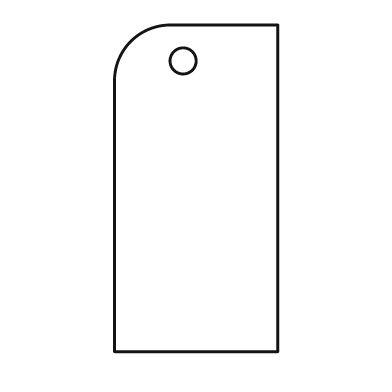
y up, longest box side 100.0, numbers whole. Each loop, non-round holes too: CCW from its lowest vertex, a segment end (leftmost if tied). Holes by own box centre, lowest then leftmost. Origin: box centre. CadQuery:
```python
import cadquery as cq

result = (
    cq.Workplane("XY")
    .moveTo(-25.0, -50.0)
    .lineTo(25.0, -50.0)
    .lineTo(25.0, 50.0)
    .lineTo(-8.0, 50.0)
    .threePointArc((-20.0, 45.0), (-25.0, 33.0))
    .close()
    .moveTo(-4.0, 39.0)
    .circle(4.0)
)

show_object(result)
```